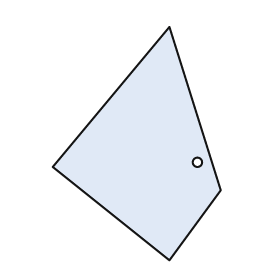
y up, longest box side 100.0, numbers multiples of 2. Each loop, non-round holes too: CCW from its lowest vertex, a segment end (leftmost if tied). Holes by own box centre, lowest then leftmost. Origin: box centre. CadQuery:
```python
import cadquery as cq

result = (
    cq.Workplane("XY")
    .moveTo(14.0, -50.0)
    .lineTo(36.0, -20.0)
    .lineTo(14.0, 50.0)
    .lineTo(-36.0, -10.0)
    .close()
    .moveTo(26.0, -8.0)
    .circle(2.0)
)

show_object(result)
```